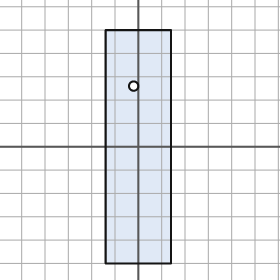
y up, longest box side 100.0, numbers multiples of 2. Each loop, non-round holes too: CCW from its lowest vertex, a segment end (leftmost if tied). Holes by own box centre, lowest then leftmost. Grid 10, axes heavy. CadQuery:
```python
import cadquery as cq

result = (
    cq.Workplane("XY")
    .moveTo(-14.0, -50.0)
    .lineTo(14.0, -50.0)
    .lineTo(14.0, 50.0)
    .lineTo(-14.0, 50.0)
    .close()
    .moveTo(-2.0, 26.0)
    .circle(2.0)
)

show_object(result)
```